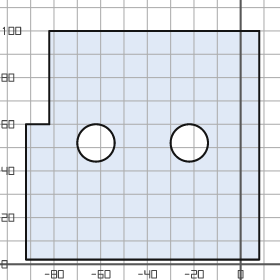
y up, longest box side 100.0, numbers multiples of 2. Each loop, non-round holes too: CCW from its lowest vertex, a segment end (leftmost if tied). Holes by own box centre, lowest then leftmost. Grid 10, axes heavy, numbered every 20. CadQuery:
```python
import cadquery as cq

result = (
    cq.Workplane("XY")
    .moveTo(-92.0, 2.0)
    .lineTo(8.0, 2.0)
    .lineTo(8.0, 100.0)
    .lineTo(-82.0, 100.0)
    .lineTo(-82.0, 60.0)
    .lineTo(-92.0, 60.0)
    .close()
    .moveTo(-62.0, 52.0)
    .circle(8.0)
    .moveTo(-22.0, 52.0)
    .circle(8.0)
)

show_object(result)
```